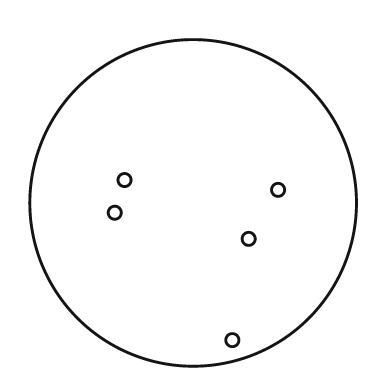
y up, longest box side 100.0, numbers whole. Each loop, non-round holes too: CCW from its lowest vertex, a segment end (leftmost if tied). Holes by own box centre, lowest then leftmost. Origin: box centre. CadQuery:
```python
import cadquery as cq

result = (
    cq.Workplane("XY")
    .moveTo(0.0, 0.0)
    .circle(50.0)
    .moveTo(12.0, -42.0)
    .circle(2.0)
    .moveTo(17.0, -11.0)
    .circle(2.0)
    .moveTo(-24.0, -3.0)
    .circle(2.0)
    .moveTo(26.0, 4.0)
    .circle(2.0)
    .moveTo(-21.0, 7.0)
    .circle(2.0)
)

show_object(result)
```